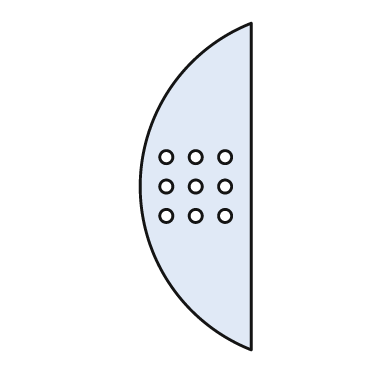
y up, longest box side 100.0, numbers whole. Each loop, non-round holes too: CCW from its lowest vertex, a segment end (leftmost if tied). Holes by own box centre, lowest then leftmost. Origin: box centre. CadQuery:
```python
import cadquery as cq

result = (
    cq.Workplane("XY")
    .moveTo(17.0, -50.0)
    .lineTo(17.0, 50.0)
    .threePointArc((-17.0, 0.0), (17.0, -50.0))
    .close()
    .moveTo(-9.0, -9.0)
    .circle(2.0)
    .moveTo(0.0, -9.0)
    .circle(2.0)
    .moveTo(9.0, -9.0)
    .circle(2.0)
    .moveTo(-9.0, 0.0)
    .circle(2.0)
    .moveTo(0.0, 0.0)
    .circle(2.0)
    .moveTo(9.0, 0.0)
    .circle(2.0)
    .moveTo(-9.0, 9.0)
    .circle(2.0)
    .moveTo(0.0, 9.0)
    .circle(2.0)
    .moveTo(9.0, 9.0)
    .circle(2.0)
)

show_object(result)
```